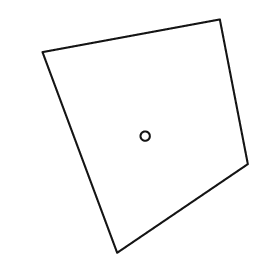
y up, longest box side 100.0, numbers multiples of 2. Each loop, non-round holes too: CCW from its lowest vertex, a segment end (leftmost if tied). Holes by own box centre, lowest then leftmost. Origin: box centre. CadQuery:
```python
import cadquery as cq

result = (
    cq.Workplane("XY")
    .moveTo(-12.0, -50.0)
    .lineTo(44.0, -12.0)
    .lineTo(32.0, 50.0)
    .lineTo(-44.0, 36.0)
    .close()
    .moveTo(0.0, 0.0)
    .circle(2.0)
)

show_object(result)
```